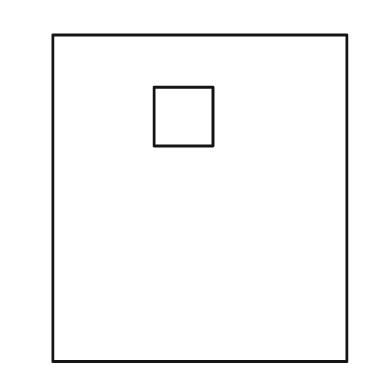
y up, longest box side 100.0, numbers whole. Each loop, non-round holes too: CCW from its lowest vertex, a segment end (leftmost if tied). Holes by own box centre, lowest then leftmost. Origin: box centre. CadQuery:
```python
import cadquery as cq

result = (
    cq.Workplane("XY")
    .moveTo(-45.0, -50.0)
    .lineTo(45.0, -50.0)
    .lineTo(45.0, 50.0)
    .lineTo(-45.0, 50.0)
    .close()
    .moveTo(-14.0, 16.0)
    .lineTo(4.0, 16.0)
    .lineTo(4.0, 34.0)
    .lineTo(-14.0, 34.0)
    .close()
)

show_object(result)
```